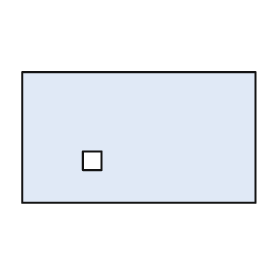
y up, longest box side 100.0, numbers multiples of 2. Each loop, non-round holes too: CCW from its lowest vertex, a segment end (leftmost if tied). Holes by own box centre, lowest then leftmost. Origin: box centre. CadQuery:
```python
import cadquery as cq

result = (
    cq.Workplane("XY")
    .moveTo(-50.0, -28.0)
    .lineTo(50.0, -28.0)
    .lineTo(50.0, 28.0)
    .lineTo(-50.0, 28.0)
    .close()
    .moveTo(-24.0, -14.0)
    .lineTo(-16.0, -14.0)
    .lineTo(-16.0, -6.0)
    .lineTo(-24.0, -6.0)
    .close()
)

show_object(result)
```